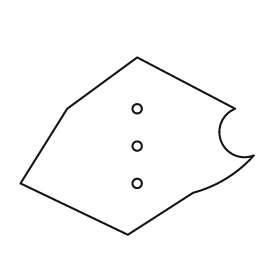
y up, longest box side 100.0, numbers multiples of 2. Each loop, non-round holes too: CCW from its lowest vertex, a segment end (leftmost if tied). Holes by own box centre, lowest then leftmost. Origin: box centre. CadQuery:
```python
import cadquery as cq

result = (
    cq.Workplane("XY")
    .moveTo(-4.0, -38.0)
    .lineTo(24.0, -20.0)
    .threePointArc((38.0, -14.0), (50.0, -4.0))
    .threePointArc((36.0, 2.0), (42.0, 16.0))
    .lineTo(0.0, 38.0)
    .lineTo(-30.0, 16.0)
    .lineTo(-50.0, -16.0)
    .close()
    .moveTo(0.0, -16.0)
    .circle(2.0)
    .moveTo(0.0, 0.0)
    .circle(2.0)
    .moveTo(0.0, 16.0)
    .circle(2.0)
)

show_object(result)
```